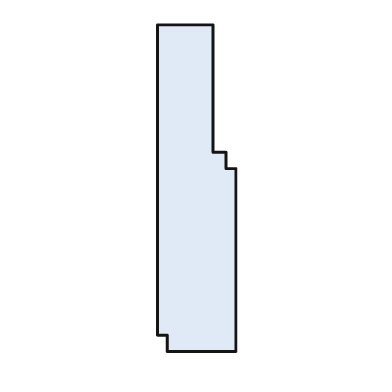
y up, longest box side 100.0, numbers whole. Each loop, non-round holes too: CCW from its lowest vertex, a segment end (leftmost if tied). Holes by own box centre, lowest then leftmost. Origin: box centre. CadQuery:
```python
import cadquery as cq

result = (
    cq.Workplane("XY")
    .moveTo(-9.0, -50.0)
    .lineTo(12.0, -50.0)
    .lineTo(12.0, 6.0)
    .lineTo(9.0, 6.0)
    .lineTo(9.0, 11.0)
    .lineTo(5.0, 11.0)
    .lineTo(5.0, 50.0)
    .lineTo(-12.0, 50.0)
    .lineTo(-12.0, -45.0)
    .lineTo(-9.0, -45.0)
    .close()
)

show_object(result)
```